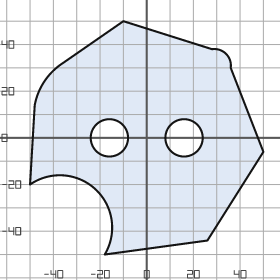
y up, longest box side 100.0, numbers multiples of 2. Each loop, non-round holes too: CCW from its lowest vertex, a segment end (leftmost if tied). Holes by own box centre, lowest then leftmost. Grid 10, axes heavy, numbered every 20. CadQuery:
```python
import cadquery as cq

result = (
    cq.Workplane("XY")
    .moveTo(-18.0, -50.0)
    .lineTo(26.0, -44.0)
    .lineTo(50.0, -6.0)
    .lineTo(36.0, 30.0)
    .threePointArc((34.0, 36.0), (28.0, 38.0))
    .lineTo(-10.0, 50.0)
    .lineTo(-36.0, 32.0)
    .threePointArc((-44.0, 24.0), (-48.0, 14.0))
    .lineTo(-50.0, -20.0)
    .threePointArc((-22.0, -22.0), (-18.0, -50.0))
    .close()
    .moveTo(-16.0, 0.0)
    .circle(8.0)
    .moveTo(16.0, 0.0)
    .circle(8.0)
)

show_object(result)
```